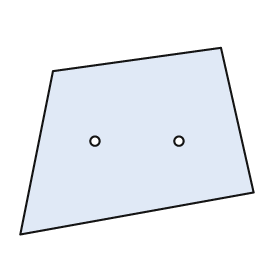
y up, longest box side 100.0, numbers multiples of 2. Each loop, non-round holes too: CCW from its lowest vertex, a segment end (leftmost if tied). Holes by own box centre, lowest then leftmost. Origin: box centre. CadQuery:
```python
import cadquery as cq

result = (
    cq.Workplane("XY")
    .moveTo(-50.0, -40.0)
    .lineTo(50.0, -22.0)
    .lineTo(36.0, 40.0)
    .lineTo(-36.0, 30.0)
    .close()
    .moveTo(-18.0, 0.0)
    .circle(2.0)
    .moveTo(18.0, 0.0)
    .circle(2.0)
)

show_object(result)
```